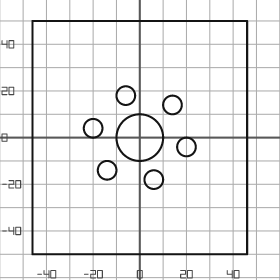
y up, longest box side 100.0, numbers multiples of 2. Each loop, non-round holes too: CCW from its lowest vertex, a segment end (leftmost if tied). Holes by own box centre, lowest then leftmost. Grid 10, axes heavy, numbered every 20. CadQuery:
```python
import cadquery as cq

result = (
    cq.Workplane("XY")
    .moveTo(-46.0, -50.0)
    .lineTo(46.0, -50.0)
    .lineTo(46.0, 50.0)
    .lineTo(-46.0, 50.0)
    .close()
    .moveTo(6.0, -18.0)
    .circle(4.0)
    .moveTo(-14.0, -14.0)
    .circle(4.0)
    .moveTo(20.0, -4.0)
    .circle(4.0)
    .moveTo(0.0, 0.0)
    .circle(10.0)
    .moveTo(-20.0, 4.0)
    .circle(4.0)
    .moveTo(14.0, 14.0)
    .circle(4.0)
    .moveTo(-6.0, 18.0)
    .circle(4.0)
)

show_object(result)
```